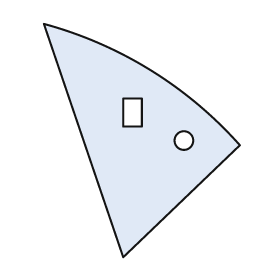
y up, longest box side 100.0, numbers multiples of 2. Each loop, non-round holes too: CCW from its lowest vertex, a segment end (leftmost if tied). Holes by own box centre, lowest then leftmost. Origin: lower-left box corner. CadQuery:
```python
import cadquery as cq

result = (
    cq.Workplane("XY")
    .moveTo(34.0, 0.0)
    .lineTo(84.0, 48.0)
    .threePointArc((46.0, 80.0), (0.0, 100.0))
    .close()
    .moveTo(60.0, 50.0)
    .circle(4.0)
    .moveTo(34.0, 56.0)
    .lineTo(42.0, 56.0)
    .lineTo(42.0, 68.0)
    .lineTo(34.0, 68.0)
    .close()
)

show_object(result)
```